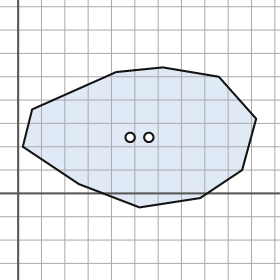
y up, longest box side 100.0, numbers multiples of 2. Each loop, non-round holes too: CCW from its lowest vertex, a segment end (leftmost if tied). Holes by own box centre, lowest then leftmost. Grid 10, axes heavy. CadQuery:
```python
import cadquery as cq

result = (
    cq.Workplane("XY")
    .moveTo(52.0, -6.0)
    .lineTo(78.0, -2.0)
    .lineTo(96.0, 10.0)
    .lineTo(102.0, 32.0)
    .lineTo(86.0, 50.0)
    .lineTo(62.0, 54.0)
    .lineTo(42.0, 52.0)
    .lineTo(6.0, 36.0)
    .lineTo(2.0, 20.0)
    .lineTo(26.0, 4.0)
    .close()
    .moveTo(48.0, 24.0)
    .circle(2.0)
    .moveTo(56.0, 24.0)
    .circle(2.0)
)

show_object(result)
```